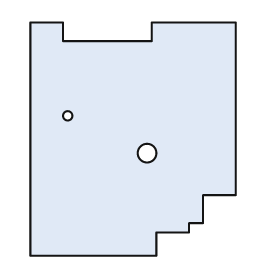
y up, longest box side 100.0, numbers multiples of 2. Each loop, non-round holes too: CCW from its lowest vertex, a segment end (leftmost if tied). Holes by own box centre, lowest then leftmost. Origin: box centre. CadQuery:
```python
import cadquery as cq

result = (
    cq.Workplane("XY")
    .moveTo(-44.0, -50.0)
    .lineTo(10.0, -50.0)
    .lineTo(10.0, -40.0)
    .lineTo(24.0, -40.0)
    .lineTo(24.0, -36.0)
    .lineTo(30.0, -36.0)
    .lineTo(30.0, -24.0)
    .lineTo(44.0, -24.0)
    .lineTo(44.0, 50.0)
    .lineTo(8.0, 50.0)
    .lineTo(8.0, 42.0)
    .lineTo(-30.0, 42.0)
    .lineTo(-30.0, 50.0)
    .lineTo(-44.0, 50.0)
    .close()
    .moveTo(6.0, -6.0)
    .circle(4.0)
    .moveTo(-28.0, 10.0)
    .circle(2.0)
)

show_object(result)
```